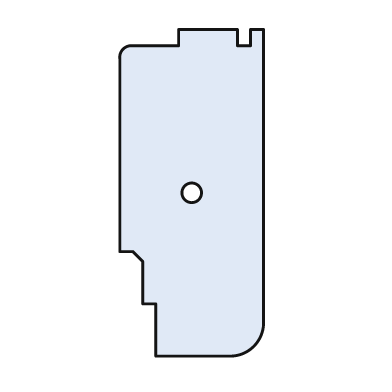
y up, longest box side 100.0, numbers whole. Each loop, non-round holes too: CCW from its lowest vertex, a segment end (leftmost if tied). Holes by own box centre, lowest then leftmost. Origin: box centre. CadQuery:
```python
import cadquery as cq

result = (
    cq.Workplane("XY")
    .moveTo(-11.0, -50.0)
    .lineTo(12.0, -50.0)
    .threePointArc((19.0, -47.0), (22.0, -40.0))
    .lineTo(22.0, 50.0)
    .lineTo(18.0, 50.0)
    .lineTo(18.0, 45.0)
    .lineTo(14.0, 45.0)
    .lineTo(14.0, 50.0)
    .lineTo(-4.0, 50.0)
    .lineTo(-4.0, 45.0)
    .lineTo(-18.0, 45.0)
    .threePointArc((-21.0, 44.0), (-22.0, 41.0))
    .lineTo(-22.0, -18.0)
    .lineTo(-18.0, -18.0)
    .lineTo(-15.0, -21.0)
    .lineTo(-15.0, -34.0)
    .lineTo(-11.0, -34.0)
    .close()
    .moveTo(0.0, 0.0)
    .circle(3.0)
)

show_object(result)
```